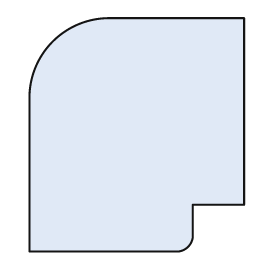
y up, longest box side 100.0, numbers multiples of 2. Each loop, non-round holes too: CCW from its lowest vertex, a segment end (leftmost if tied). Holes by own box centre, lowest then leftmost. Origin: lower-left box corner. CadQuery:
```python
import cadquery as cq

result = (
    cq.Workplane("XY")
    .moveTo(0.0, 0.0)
    .lineTo(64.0, 0.0)
    .threePointArc((68.0, 2.0), (70.0, 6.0))
    .lineTo(70.0, 20.0)
    .lineTo(92.0, 20.0)
    .lineTo(92.0, 100.0)
    .lineTo(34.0, 100.0)
    .threePointArc((10.0, 90.0), (0.0, 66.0))
    .close()
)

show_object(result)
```